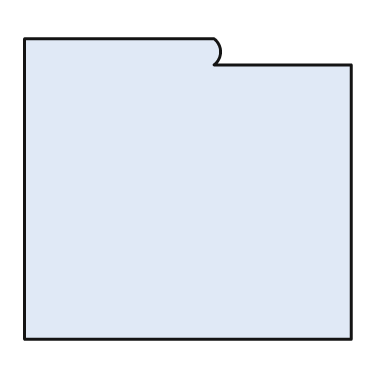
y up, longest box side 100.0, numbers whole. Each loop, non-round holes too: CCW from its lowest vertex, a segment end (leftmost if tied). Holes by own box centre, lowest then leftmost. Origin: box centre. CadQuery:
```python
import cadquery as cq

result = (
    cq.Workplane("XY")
    .moveTo(-50.0, -46.0)
    .lineTo(50.0, -46.0)
    .lineTo(50.0, 38.0)
    .lineTo(8.0, 38.0)
    .threePointArc((10.0, 42.0), (8.0, 46.0))
    .lineTo(-50.0, 46.0)
    .close()
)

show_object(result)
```